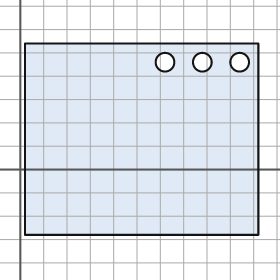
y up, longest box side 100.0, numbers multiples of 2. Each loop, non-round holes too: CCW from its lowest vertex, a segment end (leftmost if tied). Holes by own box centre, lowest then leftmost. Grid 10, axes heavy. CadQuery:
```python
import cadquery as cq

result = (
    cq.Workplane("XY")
    .moveTo(2.0, -28.0)
    .lineTo(102.0, -28.0)
    .lineTo(102.0, 54.0)
    .lineTo(2.0, 54.0)
    .close()
    .moveTo(62.0, 46.0)
    .circle(4.0)
    .moveTo(78.0, 46.0)
    .circle(4.0)
    .moveTo(94.0, 46.0)
    .circle(4.0)
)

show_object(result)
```